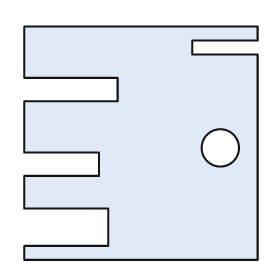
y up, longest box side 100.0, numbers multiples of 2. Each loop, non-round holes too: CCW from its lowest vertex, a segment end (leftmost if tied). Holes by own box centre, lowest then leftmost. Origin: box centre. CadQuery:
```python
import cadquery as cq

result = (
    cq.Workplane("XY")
    .moveTo(-50.0, -50.0)
    .lineTo(50.0, -50.0)
    .lineTo(50.0, 38.0)
    .lineTo(22.0, 38.0)
    .lineTo(22.0, 44.0)
    .lineTo(50.0, 44.0)
    .lineTo(50.0, 50.0)
    .lineTo(-50.0, 50.0)
    .lineTo(-50.0, 28.0)
    .lineTo(-10.0, 28.0)
    .lineTo(-10.0, 18.0)
    .lineTo(-50.0, 18.0)
    .lineTo(-50.0, -4.0)
    .lineTo(-18.0, -4.0)
    .lineTo(-18.0, -14.0)
    .lineTo(-50.0, -14.0)
    .lineTo(-50.0, -28.0)
    .lineTo(-14.0, -28.0)
    .lineTo(-14.0, -44.0)
    .lineTo(-50.0, -44.0)
    .close()
    .moveTo(34.0, -2.0)
    .circle(8.0)
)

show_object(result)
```